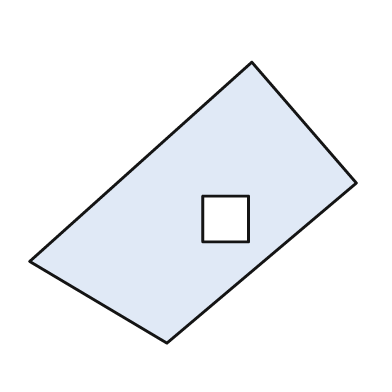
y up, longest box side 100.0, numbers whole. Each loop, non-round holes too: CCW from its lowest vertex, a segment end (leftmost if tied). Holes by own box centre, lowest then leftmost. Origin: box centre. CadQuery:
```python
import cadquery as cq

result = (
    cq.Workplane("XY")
    .moveTo(-8.0, -43.0)
    .lineTo(50.0, 6.0)
    .lineTo(18.0, 43.0)
    .lineTo(-50.0, -18.0)
    .close()
    .moveTo(3.0, -12.0)
    .lineTo(17.0, -12.0)
    .lineTo(17.0, 2.0)
    .lineTo(3.0, 2.0)
    .close()
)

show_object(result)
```